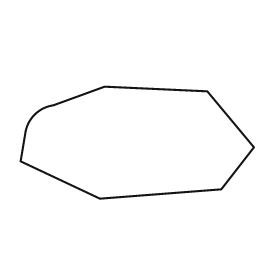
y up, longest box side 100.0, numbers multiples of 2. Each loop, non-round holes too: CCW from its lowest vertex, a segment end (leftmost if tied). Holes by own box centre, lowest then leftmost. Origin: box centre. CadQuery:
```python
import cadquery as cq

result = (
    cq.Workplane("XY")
    .moveTo(-16.0, -24.0)
    .lineTo(36.0, -20.0)
    .lineTo(50.0, -2.0)
    .lineTo(30.0, 22.0)
    .lineTo(-14.0, 24.0)
    .lineTo(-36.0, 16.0)
    .threePointArc((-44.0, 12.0), (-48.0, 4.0))
    .lineTo(-50.0, -8.0)
    .close()
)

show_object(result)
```